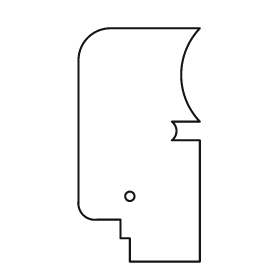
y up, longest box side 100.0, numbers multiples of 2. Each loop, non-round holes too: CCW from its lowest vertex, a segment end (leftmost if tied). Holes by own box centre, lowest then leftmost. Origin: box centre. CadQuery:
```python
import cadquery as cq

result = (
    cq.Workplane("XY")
    .moveTo(-4.0, -50.0)
    .lineTo(26.0, -50.0)
    .lineTo(26.0, 2.0)
    .lineTo(14.0, 2.0)
    .threePointArc((16.0, 6.0), (14.0, 10.0))
    .lineTo(26.0, 10.0)
    .threePointArc((18.0, 30.0), (26.0, 50.0))
    .lineTo(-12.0, 50.0)
    .threePointArc((-22.0, 46.0), (-26.0, 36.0))
    .lineTo(-26.0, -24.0)
    .threePointArc((-24.0, -30.0), (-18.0, -32.0))
    .lineTo(-8.0, -32.0)
    .lineTo(-8.0, -40.0)
    .lineTo(-4.0, -40.0)
    .close()
    .moveTo(-4.0, -22.0)
    .circle(2.0)
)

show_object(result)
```